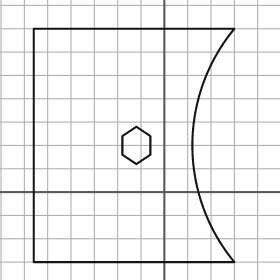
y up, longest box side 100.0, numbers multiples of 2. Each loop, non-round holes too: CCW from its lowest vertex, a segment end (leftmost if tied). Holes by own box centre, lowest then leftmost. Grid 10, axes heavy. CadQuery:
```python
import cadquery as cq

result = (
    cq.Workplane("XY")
    .moveTo(-56.0, -30.0)
    .lineTo(30.0, -30.0)
    .threePointArc((12.0, 20.0), (30.0, 70.0))
    .lineTo(-56.0, 70.0)
    .close()
    .moveTo(-12.0, 12.0)
    .lineTo(-6.0, 16.0)
    .lineTo(-6.0, 24.0)
    .lineTo(-12.0, 28.0)
    .lineTo(-18.0, 24.0)
    .lineTo(-18.0, 16.0)
    .close()
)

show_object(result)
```